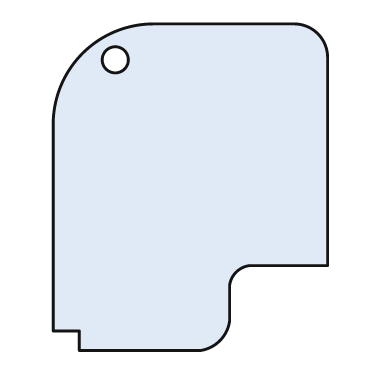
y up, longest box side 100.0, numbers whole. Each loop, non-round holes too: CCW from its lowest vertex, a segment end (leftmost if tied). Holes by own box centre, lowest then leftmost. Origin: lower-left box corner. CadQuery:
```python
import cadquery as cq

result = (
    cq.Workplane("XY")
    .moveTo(8.0, 0.0)
    .lineTo(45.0, 0.0)
    .threePointArc((51.0, 3.0), (54.0, 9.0))
    .lineTo(54.0, 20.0)
    .threePointArc((56.0, 24.0), (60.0, 26.0))
    .lineTo(84.0, 26.0)
    .lineTo(84.0, 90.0)
    .threePointArc((81.0, 97.0), (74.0, 100.0))
    .lineTo(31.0, 100.0)
    .threePointArc((9.0, 91.0), (0.0, 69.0))
    .lineTo(0.0, 6.0)
    .lineTo(8.0, 6.0)
    .close()
    .moveTo(19.0, 89.0)
    .circle(4.0)
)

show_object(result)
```